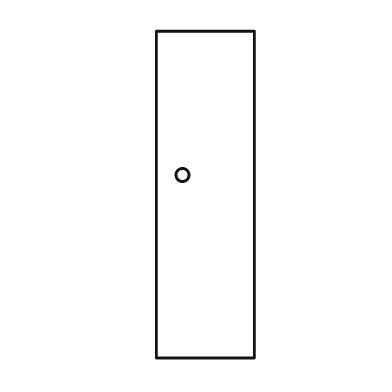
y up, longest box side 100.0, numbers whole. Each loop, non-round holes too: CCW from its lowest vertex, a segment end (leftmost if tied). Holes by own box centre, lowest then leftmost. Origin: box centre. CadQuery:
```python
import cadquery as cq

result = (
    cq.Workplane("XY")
    .moveTo(-15.0, -50.0)
    .lineTo(15.0, -50.0)
    .lineTo(15.0, 50.0)
    .lineTo(-15.0, 50.0)
    .close()
    .moveTo(-7.0, 6.0)
    .circle(2.0)
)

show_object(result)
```